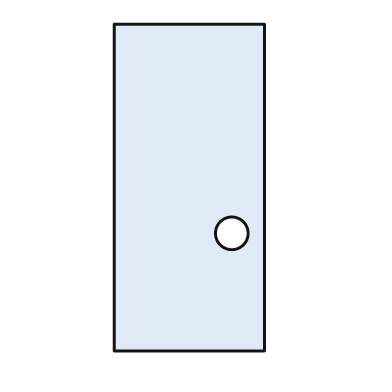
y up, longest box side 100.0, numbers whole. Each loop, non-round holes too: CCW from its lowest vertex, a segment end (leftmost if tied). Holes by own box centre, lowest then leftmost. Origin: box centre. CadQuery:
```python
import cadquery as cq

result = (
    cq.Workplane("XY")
    .moveTo(-23.0, -50.0)
    .lineTo(23.0, -50.0)
    .lineTo(23.0, 50.0)
    .lineTo(-23.0, 50.0)
    .close()
    .moveTo(13.0, -14.0)
    .circle(5.0)
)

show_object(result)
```